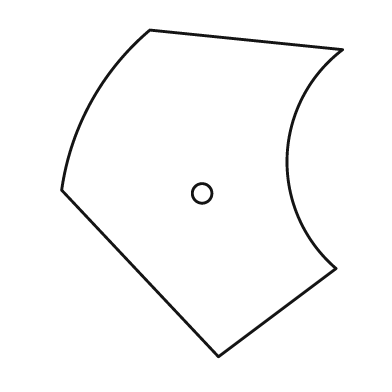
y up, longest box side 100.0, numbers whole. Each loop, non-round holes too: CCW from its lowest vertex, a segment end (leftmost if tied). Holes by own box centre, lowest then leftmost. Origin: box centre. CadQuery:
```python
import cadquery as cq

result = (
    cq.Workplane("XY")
    .moveTo(5.0, -50.0)
    .lineTo(41.0, -23.0)
    .threePointArc((26.0, 11.0), (43.0, 44.0))
    .lineTo(-16.0, 50.0)
    .threePointArc((-34.0, 28.0), (-43.0, 1.0))
    .close()
    .moveTo(0.0, 0.0)
    .circle(3.0)
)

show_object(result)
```